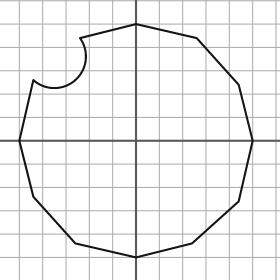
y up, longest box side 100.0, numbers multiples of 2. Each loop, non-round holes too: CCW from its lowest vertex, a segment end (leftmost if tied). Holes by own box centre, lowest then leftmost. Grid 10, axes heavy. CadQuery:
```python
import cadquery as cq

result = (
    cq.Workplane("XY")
    .moveTo(0.0, -50.0)
    .lineTo(24.0, -44.0)
    .lineTo(44.0, -26.0)
    .lineTo(50.0, 0.0)
    .lineTo(44.0, 24.0)
    .lineTo(26.0, 44.0)
    .lineTo(0.0, 50.0)
    .lineTo(-24.0, 44.0)
    .threePointArc((-26.0, 26.0), (-44.0, 26.0))
    .lineTo(-50.0, 0.0)
    .lineTo(-44.0, -24.0)
    .lineTo(-26.0, -44.0)
    .close()
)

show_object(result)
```